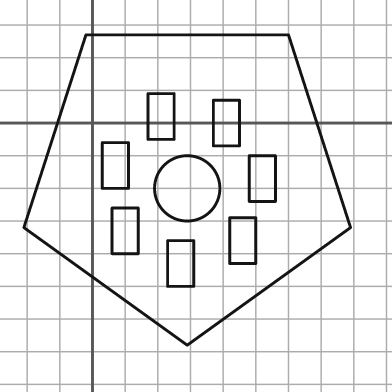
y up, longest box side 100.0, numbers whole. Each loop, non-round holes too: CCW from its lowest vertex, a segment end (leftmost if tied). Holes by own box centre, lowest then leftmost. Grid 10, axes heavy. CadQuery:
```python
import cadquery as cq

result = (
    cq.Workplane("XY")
    .moveTo(29.0, -68.0)
    .lineTo(79.0, -32.0)
    .lineTo(60.0, 27.0)
    .lineTo(-2.0, 27.0)
    .lineTo(-21.0, -32.0)
    .close()
    .moveTo(23.0, -50.0)
    .lineTo(31.0, -50.0)
    .lineTo(31.0, -36.0)
    .lineTo(23.0, -36.0)
    .close()
    .moveTo(42.0, -43.0)
    .lineTo(50.0, -43.0)
    .lineTo(50.0, -29.0)
    .lineTo(42.0, -29.0)
    .close()
    .moveTo(6.0, -40.0)
    .lineTo(14.0, -40.0)
    .lineTo(14.0, -26.0)
    .lineTo(6.0, -26.0)
    .close()
    .moveTo(29.0, -20.0)
    .circle(10.0)
    .moveTo(48.0, -24.0)
    .lineTo(56.0, -24.0)
    .lineTo(56.0, -10.0)
    .lineTo(48.0, -10.0)
    .close()
    .moveTo(3.0, -20.0)
    .lineTo(11.0, -20.0)
    .lineTo(11.0, -6.0)
    .lineTo(3.0, -6.0)
    .close()
    .moveTo(37.0, -7.0)
    .lineTo(45.0, -7.0)
    .lineTo(45.0, 7.0)
    .lineTo(37.0, 7.0)
    .close()
    .moveTo(17.0, -5.0)
    .lineTo(25.0, -5.0)
    .lineTo(25.0, 9.0)
    .lineTo(17.0, 9.0)
    .close()
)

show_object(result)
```